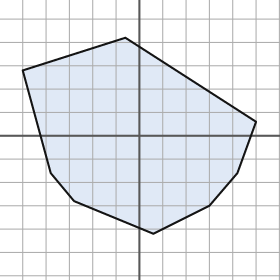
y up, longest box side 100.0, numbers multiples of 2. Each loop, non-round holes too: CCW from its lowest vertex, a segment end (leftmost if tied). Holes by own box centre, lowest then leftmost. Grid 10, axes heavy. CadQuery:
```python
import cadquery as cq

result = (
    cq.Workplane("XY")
    .moveTo(6.0, -42.0)
    .lineTo(30.0, -30.0)
    .lineTo(42.0, -16.0)
    .lineTo(50.0, 6.0)
    .lineTo(-6.0, 42.0)
    .lineTo(-50.0, 28.0)
    .lineTo(-38.0, -16.0)
    .lineTo(-28.0, -28.0)
    .close()
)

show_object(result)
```